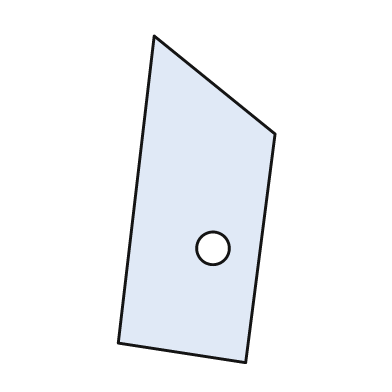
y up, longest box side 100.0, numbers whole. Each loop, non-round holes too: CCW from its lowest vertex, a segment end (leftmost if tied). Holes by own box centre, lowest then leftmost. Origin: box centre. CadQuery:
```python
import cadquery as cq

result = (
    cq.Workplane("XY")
    .moveTo(15.0, -50.0)
    .lineTo(24.0, 20.0)
    .lineTo(-13.0, 50.0)
    .lineTo(-24.0, -44.0)
    .close()
    .moveTo(5.0, -15.0)
    .circle(5.0)
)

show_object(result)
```